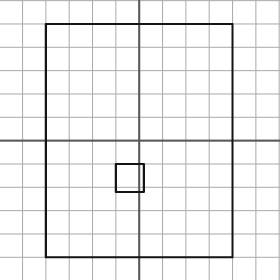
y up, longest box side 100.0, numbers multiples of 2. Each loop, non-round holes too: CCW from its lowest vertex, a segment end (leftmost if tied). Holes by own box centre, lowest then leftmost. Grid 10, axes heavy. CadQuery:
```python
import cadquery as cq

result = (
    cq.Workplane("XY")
    .moveTo(-40.0, -50.0)
    .lineTo(40.0, -50.0)
    .lineTo(40.0, 50.0)
    .lineTo(-40.0, 50.0)
    .close()
    .moveTo(-10.0, -22.0)
    .lineTo(2.0, -22.0)
    .lineTo(2.0, -10.0)
    .lineTo(-10.0, -10.0)
    .close()
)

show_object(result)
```